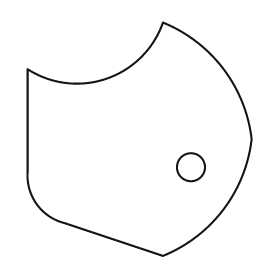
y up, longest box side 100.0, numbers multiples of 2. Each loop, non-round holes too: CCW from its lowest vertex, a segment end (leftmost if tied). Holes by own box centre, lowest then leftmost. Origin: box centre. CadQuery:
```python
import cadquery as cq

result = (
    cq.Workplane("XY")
    .moveTo(10.0, -50.0)
    .threePointArc((36.0, -30.0), (48.0, 0.0))
    .threePointArc((36.0, 30.0), (10.0, 50.0))
    .threePointArc((-14.0, 26.0), (-48.0, 30.0))
    .lineTo(-48.0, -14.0)
    .threePointArc((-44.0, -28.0), (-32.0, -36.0))
    .close()
    .moveTo(22.0, -12.0)
    .circle(6.0)
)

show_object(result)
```